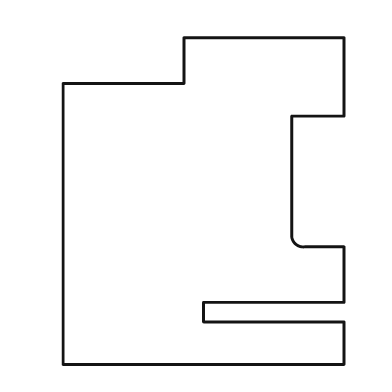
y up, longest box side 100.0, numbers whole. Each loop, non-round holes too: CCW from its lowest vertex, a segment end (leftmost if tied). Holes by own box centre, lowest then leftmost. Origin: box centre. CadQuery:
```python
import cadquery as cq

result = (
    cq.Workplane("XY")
    .moveTo(-43.0, -50.0)
    .lineTo(43.0, -50.0)
    .lineTo(43.0, -37.0)
    .lineTo(0.0, -37.0)
    .lineTo(0.0, -31.0)
    .lineTo(43.0, -31.0)
    .lineTo(43.0, -14.0)
    .lineTo(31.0, -14.0)
    .threePointArc((28.0, -13.0), (27.0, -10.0))
    .lineTo(27.0, 26.0)
    .lineTo(43.0, 26.0)
    .lineTo(43.0, 50.0)
    .lineTo(-6.0, 50.0)
    .lineTo(-6.0, 36.0)
    .lineTo(-43.0, 36.0)
    .close()
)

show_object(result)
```